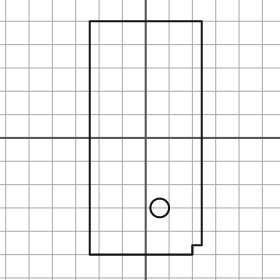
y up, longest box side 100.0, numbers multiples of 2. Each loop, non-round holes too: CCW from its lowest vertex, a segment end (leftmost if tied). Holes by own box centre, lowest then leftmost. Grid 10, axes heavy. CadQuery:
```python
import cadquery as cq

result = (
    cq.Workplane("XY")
    .moveTo(-24.0, -50.0)
    .lineTo(20.0, -50.0)
    .lineTo(20.0, -46.0)
    .lineTo(24.0, -46.0)
    .lineTo(24.0, 50.0)
    .lineTo(-24.0, 50.0)
    .close()
    .moveTo(6.0, -30.0)
    .circle(4.0)
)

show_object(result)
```